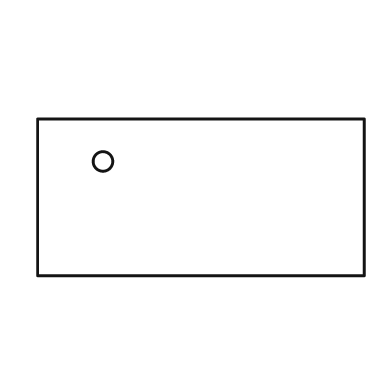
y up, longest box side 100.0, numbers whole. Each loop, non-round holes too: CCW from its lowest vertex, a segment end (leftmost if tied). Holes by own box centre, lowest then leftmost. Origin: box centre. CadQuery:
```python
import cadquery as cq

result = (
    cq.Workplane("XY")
    .moveTo(-50.0, -24.0)
    .lineTo(50.0, -24.0)
    .lineTo(50.0, 24.0)
    .lineTo(-50.0, 24.0)
    .close()
    .moveTo(-30.0, 11.0)
    .circle(3.0)
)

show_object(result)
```